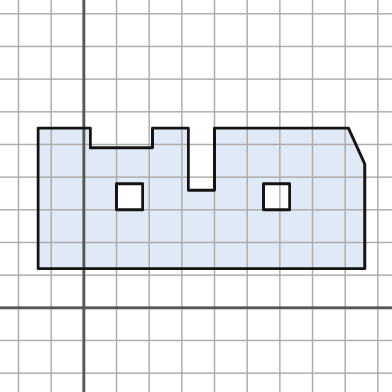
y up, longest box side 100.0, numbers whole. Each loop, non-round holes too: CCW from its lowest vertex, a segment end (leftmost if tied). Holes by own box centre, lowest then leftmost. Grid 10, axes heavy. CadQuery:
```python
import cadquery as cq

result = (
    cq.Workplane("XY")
    .moveTo(-14.0, 12.0)
    .lineTo(86.0, 12.0)
    .lineTo(86.0, 44.0)
    .lineTo(81.0, 55.0)
    .lineTo(40.0, 55.0)
    .lineTo(40.0, 36.0)
    .lineTo(32.0, 36.0)
    .lineTo(32.0, 55.0)
    .lineTo(21.0, 55.0)
    .lineTo(21.0, 49.0)
    .lineTo(2.0, 49.0)
    .lineTo(2.0, 55.0)
    .lineTo(-14.0, 55.0)
    .close()
    .moveTo(10.0, 30.0)
    .lineTo(18.0, 30.0)
    .lineTo(18.0, 38.0)
    .lineTo(10.0, 38.0)
    .close()
    .moveTo(55.0, 30.0)
    .lineTo(63.0, 30.0)
    .lineTo(63.0, 38.0)
    .lineTo(55.0, 38.0)
    .close()
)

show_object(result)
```